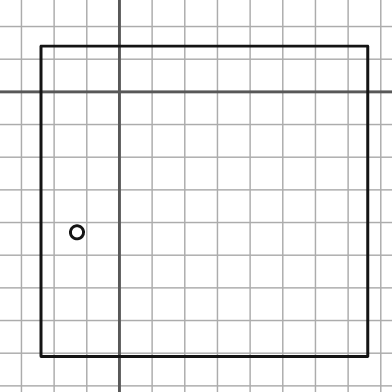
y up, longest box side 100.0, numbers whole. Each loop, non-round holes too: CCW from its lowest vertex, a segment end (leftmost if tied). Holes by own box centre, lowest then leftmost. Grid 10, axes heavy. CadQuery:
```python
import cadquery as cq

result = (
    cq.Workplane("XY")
    .moveTo(-24.0, -81.0)
    .lineTo(76.0, -81.0)
    .lineTo(76.0, 14.0)
    .lineTo(-24.0, 14.0)
    .close()
    .moveTo(-13.0, -43.0)
    .circle(2.0)
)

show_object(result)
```